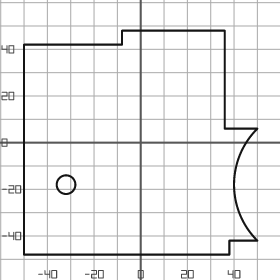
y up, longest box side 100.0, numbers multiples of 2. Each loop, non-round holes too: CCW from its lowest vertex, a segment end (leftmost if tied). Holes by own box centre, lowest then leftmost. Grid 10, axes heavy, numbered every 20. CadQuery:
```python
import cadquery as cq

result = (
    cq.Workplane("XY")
    .moveTo(-50.0, -48.0)
    .lineTo(38.0, -48.0)
    .lineTo(38.0, -42.0)
    .lineTo(50.0, -42.0)
    .threePointArc((40.0, -18.0), (50.0, 6.0))
    .lineTo(36.0, 6.0)
    .lineTo(36.0, 48.0)
    .lineTo(-8.0, 48.0)
    .lineTo(-8.0, 42.0)
    .lineTo(-50.0, 42.0)
    .close()
    .moveTo(-32.0, -18.0)
    .circle(4.0)
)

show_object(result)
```